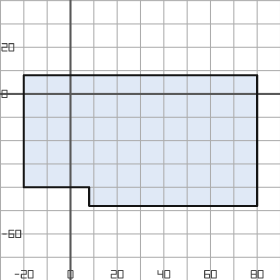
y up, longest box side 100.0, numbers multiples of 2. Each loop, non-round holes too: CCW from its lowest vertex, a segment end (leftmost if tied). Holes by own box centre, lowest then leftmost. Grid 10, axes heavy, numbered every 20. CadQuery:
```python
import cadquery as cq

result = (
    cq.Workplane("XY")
    .moveTo(8.0, -48.0)
    .lineTo(80.0, -48.0)
    .lineTo(80.0, 8.0)
    .lineTo(-20.0, 8.0)
    .lineTo(-20.0, -40.0)
    .lineTo(8.0, -40.0)
    .close()
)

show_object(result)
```